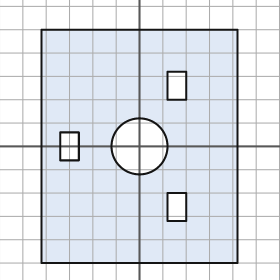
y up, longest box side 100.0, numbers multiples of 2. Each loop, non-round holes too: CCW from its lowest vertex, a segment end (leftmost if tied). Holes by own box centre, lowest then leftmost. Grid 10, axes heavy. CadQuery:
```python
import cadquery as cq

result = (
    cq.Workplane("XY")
    .moveTo(-42.0, -50.0)
    .lineTo(42.0, -50.0)
    .lineTo(42.0, 50.0)
    .lineTo(-42.0, 50.0)
    .close()
    .moveTo(12.0, -32.0)
    .lineTo(20.0, -32.0)
    .lineTo(20.0, -20.0)
    .lineTo(12.0, -20.0)
    .close()
    .moveTo(-34.0, -6.0)
    .lineTo(-26.0, -6.0)
    .lineTo(-26.0, 6.0)
    .lineTo(-34.0, 6.0)
    .close()
    .moveTo(0.0, 0.0)
    .circle(12.0)
    .moveTo(12.0, 20.0)
    .lineTo(20.0, 20.0)
    .lineTo(20.0, 32.0)
    .lineTo(12.0, 32.0)
    .close()
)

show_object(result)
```